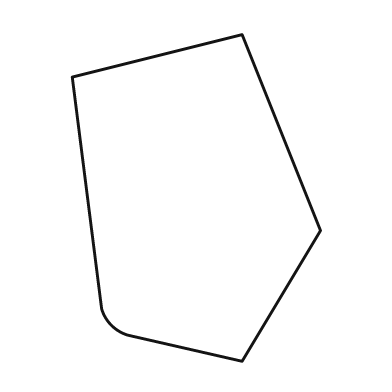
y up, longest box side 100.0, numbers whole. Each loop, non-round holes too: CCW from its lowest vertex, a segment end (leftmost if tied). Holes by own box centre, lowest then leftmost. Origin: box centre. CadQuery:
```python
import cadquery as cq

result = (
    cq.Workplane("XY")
    .moveTo(14.0, -50.0)
    .lineTo(38.0, -10.0)
    .lineTo(14.0, 50.0)
    .lineTo(-38.0, 37.0)
    .lineTo(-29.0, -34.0)
    .threePointArc((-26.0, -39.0), (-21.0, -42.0))
    .close()
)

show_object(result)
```